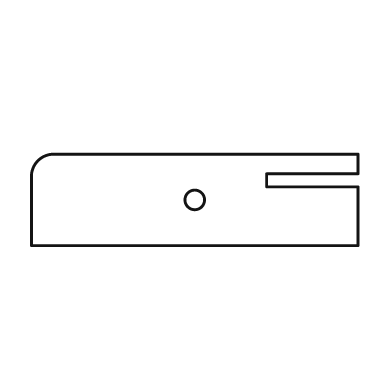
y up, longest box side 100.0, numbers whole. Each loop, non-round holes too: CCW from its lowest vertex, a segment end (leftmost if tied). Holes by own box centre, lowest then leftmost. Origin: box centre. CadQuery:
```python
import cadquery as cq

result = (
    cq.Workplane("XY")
    .moveTo(-50.0, -14.0)
    .lineTo(50.0, -14.0)
    .lineTo(50.0, 4.0)
    .lineTo(22.0, 4.0)
    .lineTo(22.0, 8.0)
    .lineTo(50.0, 8.0)
    .lineTo(50.0, 14.0)
    .lineTo(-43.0, 14.0)
    .threePointArc((-48.0, 12.0), (-50.0, 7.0))
    .close()
    .moveTo(0.0, 0.0)
    .circle(3.0)
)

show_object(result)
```